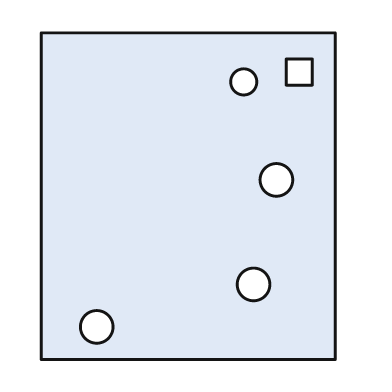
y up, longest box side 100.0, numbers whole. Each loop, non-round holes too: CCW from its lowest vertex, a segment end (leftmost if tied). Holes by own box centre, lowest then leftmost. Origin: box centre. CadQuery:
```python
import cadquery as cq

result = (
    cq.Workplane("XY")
    .moveTo(-45.0, -50.0)
    .lineTo(45.0, -50.0)
    .lineTo(45.0, 50.0)
    .lineTo(-45.0, 50.0)
    .close()
    .moveTo(-28.0, -40.0)
    .circle(5.0)
    .moveTo(20.0, -27.0)
    .circle(5.0)
    .moveTo(27.0, 5.0)
    .circle(5.0)
    .moveTo(17.0, 35.0)
    .circle(4.0)
    .moveTo(30.0, 34.0)
    .lineTo(38.0, 34.0)
    .lineTo(38.0, 42.0)
    .lineTo(30.0, 42.0)
    .close()
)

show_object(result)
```